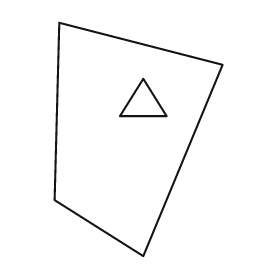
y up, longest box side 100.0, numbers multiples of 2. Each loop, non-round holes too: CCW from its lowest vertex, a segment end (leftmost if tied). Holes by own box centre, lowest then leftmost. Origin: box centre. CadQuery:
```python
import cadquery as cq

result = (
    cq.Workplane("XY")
    .moveTo(2.0, -50.0)
    .lineTo(36.0, 32.0)
    .lineTo(-34.0, 50.0)
    .lineTo(-36.0, -26.0)
    .close()
    .moveTo(-8.0, 10.0)
    .lineTo(12.0, 10.0)
    .lineTo(2.0, 26.0)
    .close()
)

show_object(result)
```